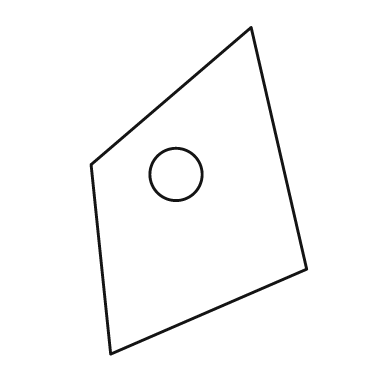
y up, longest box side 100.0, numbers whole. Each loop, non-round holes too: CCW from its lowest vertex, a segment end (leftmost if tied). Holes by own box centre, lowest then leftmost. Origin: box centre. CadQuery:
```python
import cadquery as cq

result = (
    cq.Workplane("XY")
    .moveTo(-27.0, -50.0)
    .lineTo(33.0, -24.0)
    .lineTo(16.0, 50.0)
    .lineTo(-33.0, 8.0)
    .close()
    .moveTo(-7.0, 5.0)
    .circle(8.0)
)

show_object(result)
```